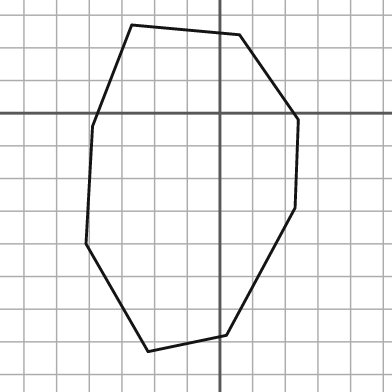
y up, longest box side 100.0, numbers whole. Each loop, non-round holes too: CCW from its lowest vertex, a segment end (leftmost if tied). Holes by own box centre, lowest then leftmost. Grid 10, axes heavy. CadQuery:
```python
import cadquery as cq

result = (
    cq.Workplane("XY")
    .moveTo(-22.0, -73.0)
    .lineTo(2.0, -68.0)
    .lineTo(23.0, -29.0)
    .lineTo(24.0, -2.0)
    .lineTo(6.0, 24.0)
    .lineTo(-27.0, 27.0)
    .lineTo(-39.0, -4.0)
    .lineTo(-41.0, -40.0)
    .close()
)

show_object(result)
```